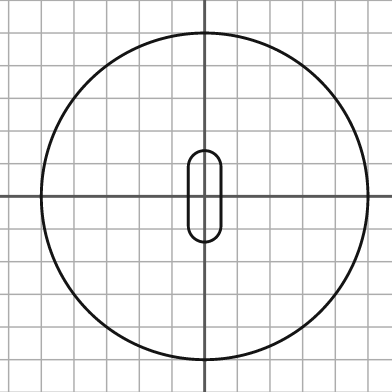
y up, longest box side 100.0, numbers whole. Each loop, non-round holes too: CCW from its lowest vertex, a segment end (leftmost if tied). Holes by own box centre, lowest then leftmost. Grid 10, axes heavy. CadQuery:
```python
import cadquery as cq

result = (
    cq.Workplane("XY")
    .moveTo(0.0, 0.0)
    .circle(50.0)
    .moveTo(-5.0, -9.0)
    .threePointArc((0.0, -14.0), (5.0, -9.0))
    .lineTo(5.0, 9.0)
    .threePointArc((0.0, 14.0), (-5.0, 9.0))
    .close()
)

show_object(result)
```